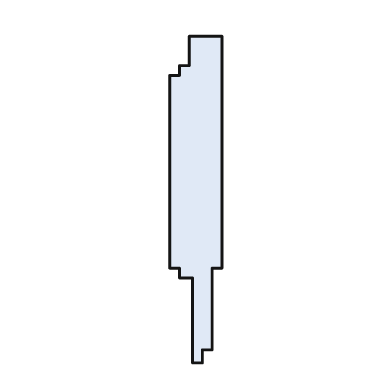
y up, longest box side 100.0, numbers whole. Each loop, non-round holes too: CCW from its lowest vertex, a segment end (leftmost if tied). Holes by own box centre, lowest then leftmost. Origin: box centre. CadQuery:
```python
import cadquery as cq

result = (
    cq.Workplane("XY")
    .moveTo(-1.0, -50.0)
    .lineTo(2.0, -50.0)
    .lineTo(2.0, -46.0)
    .lineTo(5.0, -46.0)
    .lineTo(5.0, -21.0)
    .lineTo(8.0, -21.0)
    .lineTo(8.0, 50.0)
    .lineTo(-2.0, 50.0)
    .lineTo(-2.0, 41.0)
    .lineTo(-5.0, 41.0)
    .lineTo(-5.0, 38.0)
    .lineTo(-8.0, 38.0)
    .lineTo(-8.0, -21.0)
    .lineTo(-5.0, -21.0)
    .lineTo(-5.0, -24.0)
    .lineTo(-1.0, -24.0)
    .close()
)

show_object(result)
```